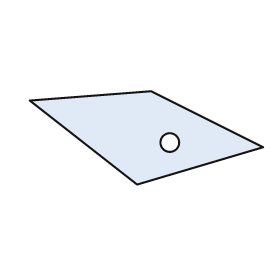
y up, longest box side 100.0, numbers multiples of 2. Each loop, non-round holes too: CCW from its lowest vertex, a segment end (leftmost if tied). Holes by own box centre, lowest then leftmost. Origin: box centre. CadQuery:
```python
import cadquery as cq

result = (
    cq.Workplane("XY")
    .moveTo(-4.0, -20.0)
    .lineTo(50.0, -4.0)
    .lineTo(2.0, 20.0)
    .lineTo(-50.0, 16.0)
    .close()
    .moveTo(10.0, -2.0)
    .circle(4.0)
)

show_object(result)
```